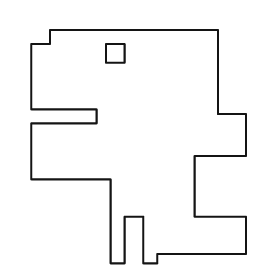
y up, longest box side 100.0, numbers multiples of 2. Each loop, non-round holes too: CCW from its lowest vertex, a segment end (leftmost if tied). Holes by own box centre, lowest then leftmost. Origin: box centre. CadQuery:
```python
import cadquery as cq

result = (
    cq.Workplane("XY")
    .moveTo(-12.0, -50.0)
    .lineTo(-6.0, -50.0)
    .lineTo(-6.0, -30.0)
    .lineTo(2.0, -30.0)
    .lineTo(2.0, -50.0)
    .lineTo(8.0, -50.0)
    .lineTo(8.0, -46.0)
    .lineTo(46.0, -46.0)
    .lineTo(46.0, -30.0)
    .lineTo(24.0, -30.0)
    .lineTo(24.0, -4.0)
    .lineTo(46.0, -4.0)
    .lineTo(46.0, 14.0)
    .lineTo(34.0, 14.0)
    .lineTo(34.0, 50.0)
    .lineTo(-38.0, 50.0)
    .lineTo(-38.0, 44.0)
    .lineTo(-46.0, 44.0)
    .lineTo(-46.0, 16.0)
    .lineTo(-18.0, 16.0)
    .lineTo(-18.0, 10.0)
    .lineTo(-46.0, 10.0)
    .lineTo(-46.0, -14.0)
    .lineTo(-12.0, -14.0)
    .close()
    .moveTo(-14.0, 36.0)
    .lineTo(-6.0, 36.0)
    .lineTo(-6.0, 44.0)
    .lineTo(-14.0, 44.0)
    .close()
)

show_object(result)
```